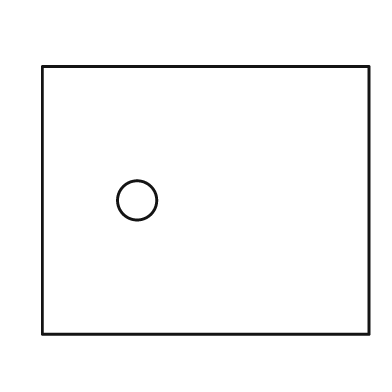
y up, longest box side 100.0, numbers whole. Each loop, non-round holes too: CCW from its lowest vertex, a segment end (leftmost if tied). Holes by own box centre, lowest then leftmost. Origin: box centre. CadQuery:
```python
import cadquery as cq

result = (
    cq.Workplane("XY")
    .moveTo(-50.0, -41.0)
    .lineTo(50.0, -41.0)
    .lineTo(50.0, 41.0)
    .lineTo(-50.0, 41.0)
    .close()
    .moveTo(-21.0, 0.0)
    .circle(6.0)
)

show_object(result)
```